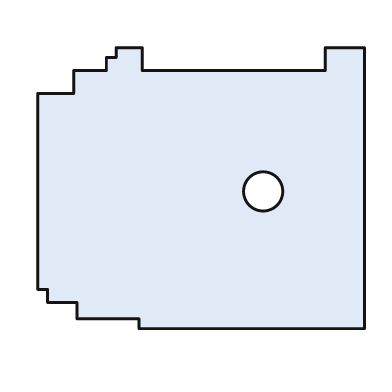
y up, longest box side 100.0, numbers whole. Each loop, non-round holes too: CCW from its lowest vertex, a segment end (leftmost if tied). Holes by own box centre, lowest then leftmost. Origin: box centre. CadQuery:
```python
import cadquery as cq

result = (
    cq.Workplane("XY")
    .moveTo(-19.0, -43.0)
    .lineTo(50.0, -43.0)
    .lineTo(50.0, 43.0)
    .lineTo(38.0, 43.0)
    .lineTo(38.0, 36.0)
    .lineTo(-18.0, 36.0)
    .lineTo(-18.0, 43.0)
    .lineTo(-26.0, 43.0)
    .lineTo(-26.0, 40.0)
    .lineTo(-29.0, 40.0)
    .lineTo(-29.0, 36.0)
    .lineTo(-39.0, 36.0)
    .lineTo(-39.0, 29.0)
    .lineTo(-50.0, 29.0)
    .lineTo(-50.0, -31.0)
    .lineTo(-47.0, -31.0)
    .lineTo(-47.0, -35.0)
    .lineTo(-38.0, -35.0)
    .lineTo(-38.0, -40.0)
    .lineTo(-19.0, -40.0)
    .close()
    .moveTo(19.0, -1.0)
    .circle(6.0)
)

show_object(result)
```